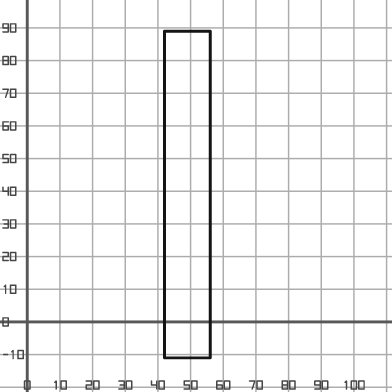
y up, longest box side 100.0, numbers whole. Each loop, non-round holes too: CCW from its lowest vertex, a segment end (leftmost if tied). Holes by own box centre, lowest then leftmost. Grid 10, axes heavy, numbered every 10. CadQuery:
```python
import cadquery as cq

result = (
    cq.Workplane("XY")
    .moveTo(42.0, -11.0)
    .lineTo(56.0, -11.0)
    .lineTo(56.0, 89.0)
    .lineTo(42.0, 89.0)
    .close()
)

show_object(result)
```